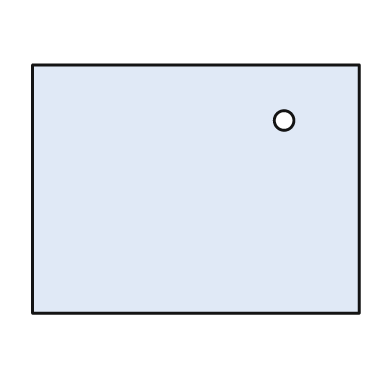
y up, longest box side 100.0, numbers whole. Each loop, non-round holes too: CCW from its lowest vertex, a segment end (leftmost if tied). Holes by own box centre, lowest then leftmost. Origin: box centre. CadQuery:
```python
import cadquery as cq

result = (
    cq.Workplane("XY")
    .moveTo(-50.0, -38.0)
    .lineTo(50.0, -38.0)
    .lineTo(50.0, 38.0)
    .lineTo(-50.0, 38.0)
    .close()
    .moveTo(27.0, 21.0)
    .circle(3.0)
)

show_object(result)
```